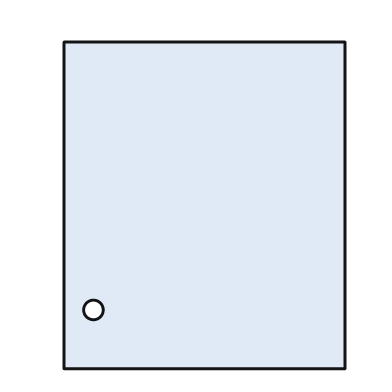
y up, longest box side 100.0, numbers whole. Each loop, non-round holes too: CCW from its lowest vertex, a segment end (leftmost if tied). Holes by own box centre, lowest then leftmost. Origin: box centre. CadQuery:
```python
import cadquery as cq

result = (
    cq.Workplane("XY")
    .moveTo(-43.0, -50.0)
    .lineTo(43.0, -50.0)
    .lineTo(43.0, 50.0)
    .lineTo(-43.0, 50.0)
    .close()
    .moveTo(-34.0, -32.0)
    .circle(3.0)
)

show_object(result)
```